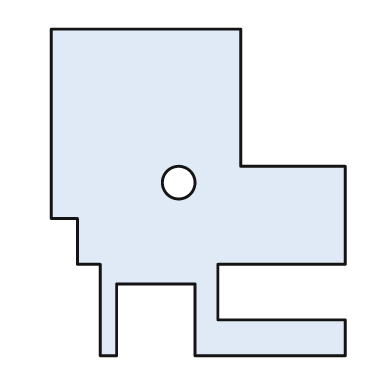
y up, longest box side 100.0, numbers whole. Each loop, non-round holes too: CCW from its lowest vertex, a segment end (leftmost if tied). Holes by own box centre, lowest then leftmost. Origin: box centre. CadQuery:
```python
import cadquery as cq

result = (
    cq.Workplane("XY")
    .moveTo(-30.0, -50.0)
    .lineTo(-25.0, -50.0)
    .lineTo(-25.0, -28.0)
    .lineTo(-1.0, -28.0)
    .lineTo(-1.0, -50.0)
    .lineTo(45.0, -50.0)
    .lineTo(45.0, -39.0)
    .lineTo(6.0, -39.0)
    .lineTo(6.0, -22.0)
    .lineTo(45.0, -22.0)
    .lineTo(45.0, 8.0)
    .lineTo(13.0, 8.0)
    .lineTo(13.0, 50.0)
    .lineTo(-45.0, 50.0)
    .lineTo(-45.0, -8.0)
    .lineTo(-37.0, -8.0)
    .lineTo(-37.0, -22.0)
    .lineTo(-30.0, -22.0)
    .close()
    .moveTo(-6.0, 3.0)
    .circle(5.0)
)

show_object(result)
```